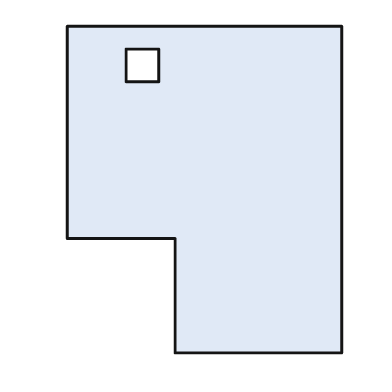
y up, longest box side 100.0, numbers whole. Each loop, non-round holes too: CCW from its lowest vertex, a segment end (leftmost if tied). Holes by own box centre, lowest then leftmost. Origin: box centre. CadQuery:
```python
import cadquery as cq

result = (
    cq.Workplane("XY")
    .moveTo(-9.0, -50.0)
    .lineTo(42.0, -50.0)
    .lineTo(42.0, 50.0)
    .lineTo(-42.0, 50.0)
    .lineTo(-42.0, -15.0)
    .lineTo(-9.0, -15.0)
    .close()
    .moveTo(-24.0, 33.0)
    .lineTo(-14.0, 33.0)
    .lineTo(-14.0, 43.0)
    .lineTo(-24.0, 43.0)
    .close()
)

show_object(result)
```